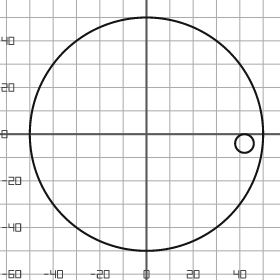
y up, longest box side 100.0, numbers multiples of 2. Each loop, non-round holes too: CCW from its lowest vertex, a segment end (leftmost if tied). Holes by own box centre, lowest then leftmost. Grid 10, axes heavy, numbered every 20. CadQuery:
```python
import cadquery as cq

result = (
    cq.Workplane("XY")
    .moveTo(0.0, 0.0)
    .circle(50.0)
    .moveTo(42.0, -4.0)
    .circle(4.0)
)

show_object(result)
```